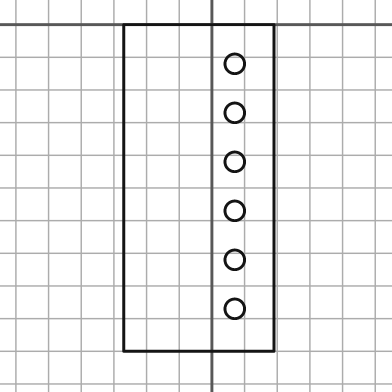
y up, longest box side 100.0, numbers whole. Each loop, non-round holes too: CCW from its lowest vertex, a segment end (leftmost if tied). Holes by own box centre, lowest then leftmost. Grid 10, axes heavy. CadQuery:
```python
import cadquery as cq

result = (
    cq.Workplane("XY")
    .moveTo(-27.0, -100.0)
    .lineTo(19.0, -100.0)
    .lineTo(19.0, 0.0)
    .lineTo(-27.0, 0.0)
    .close()
    .moveTo(7.0, -87.0)
    .circle(3.0)
    .moveTo(7.0, -72.0)
    .circle(3.0)
    .moveTo(7.0, -57.0)
    .circle(3.0)
    .moveTo(7.0, -42.0)
    .circle(3.0)
    .moveTo(7.0, -27.0)
    .circle(3.0)
    .moveTo(7.0, -12.0)
    .circle(3.0)
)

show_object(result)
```